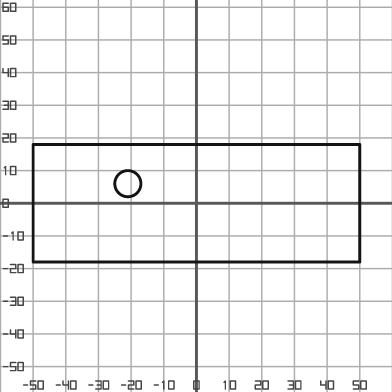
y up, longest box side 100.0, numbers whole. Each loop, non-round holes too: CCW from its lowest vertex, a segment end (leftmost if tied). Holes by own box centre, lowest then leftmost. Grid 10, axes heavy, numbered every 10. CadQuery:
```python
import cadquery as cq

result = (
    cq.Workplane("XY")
    .moveTo(-50.0, -18.0)
    .lineTo(50.0, -18.0)
    .lineTo(50.0, 18.0)
    .lineTo(-50.0, 18.0)
    .close()
    .moveTo(-21.0, 6.0)
    .circle(4.0)
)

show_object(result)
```